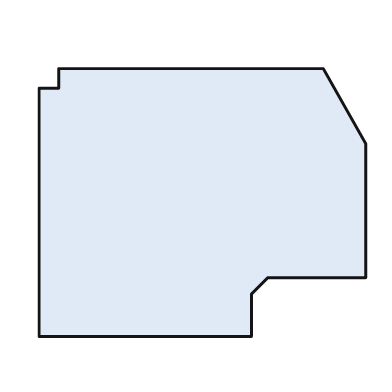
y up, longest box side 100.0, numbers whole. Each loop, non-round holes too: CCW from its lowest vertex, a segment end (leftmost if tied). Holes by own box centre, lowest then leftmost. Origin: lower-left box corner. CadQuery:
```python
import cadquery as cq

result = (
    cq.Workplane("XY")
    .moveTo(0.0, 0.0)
    .lineTo(65.0, 0.0)
    .lineTo(65.0, 13.0)
    .lineTo(70.0, 18.0)
    .lineTo(100.0, 18.0)
    .lineTo(100.0, 59.0)
    .lineTo(87.0, 82.0)
    .lineTo(6.0, 82.0)
    .lineTo(6.0, 76.0)
    .lineTo(0.0, 76.0)
    .close()
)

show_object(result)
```